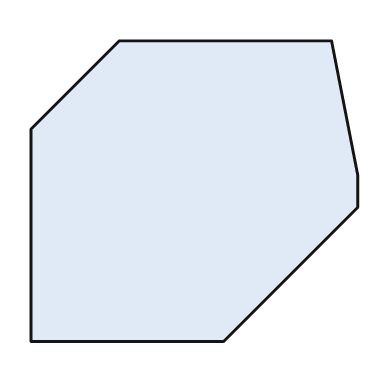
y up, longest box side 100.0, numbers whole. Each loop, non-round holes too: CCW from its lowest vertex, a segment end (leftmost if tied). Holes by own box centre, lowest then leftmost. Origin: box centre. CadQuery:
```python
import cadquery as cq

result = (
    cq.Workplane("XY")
    .moveTo(-50.0, -46.0)
    .lineTo(9.0, -46.0)
    .lineTo(50.0, -5.0)
    .lineTo(50.0, 5.0)
    .lineTo(42.0, 46.0)
    .lineTo(-23.0, 46.0)
    .lineTo(-50.0, 19.0)
    .close()
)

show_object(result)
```